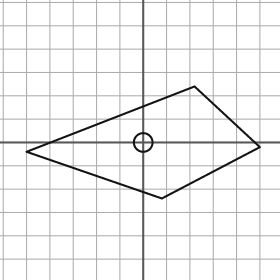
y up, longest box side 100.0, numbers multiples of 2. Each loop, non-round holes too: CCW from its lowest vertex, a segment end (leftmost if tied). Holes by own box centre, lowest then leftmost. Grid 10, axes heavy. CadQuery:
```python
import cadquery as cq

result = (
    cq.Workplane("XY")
    .moveTo(8.0, -24.0)
    .lineTo(50.0, -2.0)
    .lineTo(22.0, 24.0)
    .lineTo(-50.0, -4.0)
    .close()
    .moveTo(0.0, 0.0)
    .circle(4.0)
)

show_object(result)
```